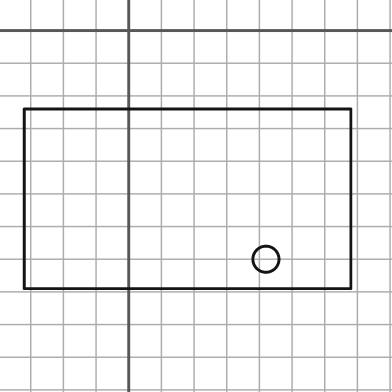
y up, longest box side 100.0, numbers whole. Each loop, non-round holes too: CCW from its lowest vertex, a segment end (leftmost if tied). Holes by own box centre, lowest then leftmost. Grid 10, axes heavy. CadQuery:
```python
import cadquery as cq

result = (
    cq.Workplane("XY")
    .moveTo(-32.0, -79.0)
    .lineTo(68.0, -79.0)
    .lineTo(68.0, -24.0)
    .lineTo(-32.0, -24.0)
    .close()
    .moveTo(42.0, -70.0)
    .circle(4.0)
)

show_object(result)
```